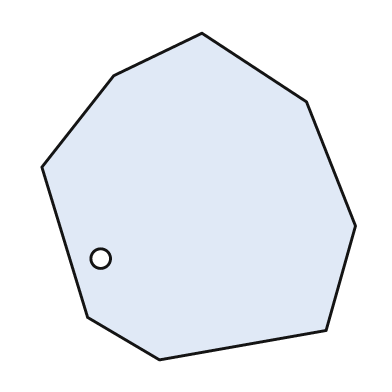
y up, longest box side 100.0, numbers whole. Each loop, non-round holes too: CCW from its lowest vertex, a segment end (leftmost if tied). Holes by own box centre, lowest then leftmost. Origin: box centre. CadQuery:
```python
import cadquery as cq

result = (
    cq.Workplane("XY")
    .moveTo(-12.0, -50.0)
    .lineTo(39.0, -41.0)
    .lineTo(48.0, -9.0)
    .lineTo(33.0, 29.0)
    .lineTo(1.0, 50.0)
    .lineTo(-26.0, 37.0)
    .lineTo(-48.0, 9.0)
    .lineTo(-34.0, -37.0)
    .close()
    .moveTo(-30.0, -19.0)
    .circle(3.0)
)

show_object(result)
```